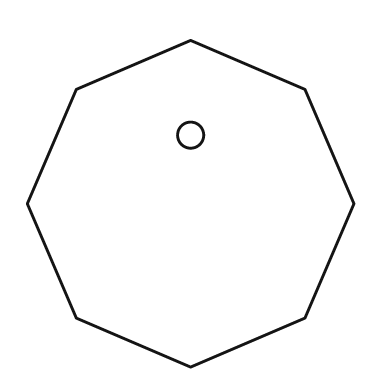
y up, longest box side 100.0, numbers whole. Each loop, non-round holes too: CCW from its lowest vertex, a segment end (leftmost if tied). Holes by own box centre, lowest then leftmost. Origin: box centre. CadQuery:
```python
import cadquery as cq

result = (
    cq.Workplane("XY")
    .moveTo(0.0, -50.0)
    .lineTo(35.0, -35.0)
    .lineTo(50.0, 0.0)
    .lineTo(35.0, 35.0)
    .lineTo(0.0, 50.0)
    .lineTo(-35.0, 35.0)
    .lineTo(-50.0, 0.0)
    .lineTo(-35.0, -35.0)
    .close()
    .moveTo(0.0, 21.0)
    .circle(4.0)
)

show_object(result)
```